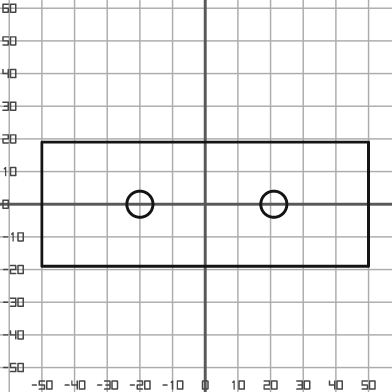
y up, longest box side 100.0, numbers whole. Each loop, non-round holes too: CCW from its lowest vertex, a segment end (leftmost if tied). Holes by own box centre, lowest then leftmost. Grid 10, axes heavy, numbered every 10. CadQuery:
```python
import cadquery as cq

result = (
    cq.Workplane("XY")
    .moveTo(-50.0, -19.0)
    .lineTo(50.0, -19.0)
    .lineTo(50.0, 19.0)
    .lineTo(-50.0, 19.0)
    .close()
    .moveTo(-20.0, 0.0)
    .circle(4.0)
    .moveTo(21.0, 0.0)
    .circle(4.0)
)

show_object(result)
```